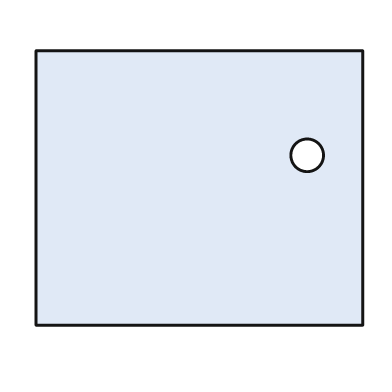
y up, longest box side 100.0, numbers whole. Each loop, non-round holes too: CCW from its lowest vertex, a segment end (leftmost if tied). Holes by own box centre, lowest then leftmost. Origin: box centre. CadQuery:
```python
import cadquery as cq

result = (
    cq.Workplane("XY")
    .moveTo(-50.0, -42.0)
    .lineTo(50.0, -42.0)
    .lineTo(50.0, 42.0)
    .lineTo(-50.0, 42.0)
    .close()
    .moveTo(33.0, 10.0)
    .circle(5.0)
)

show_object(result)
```